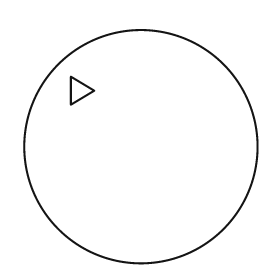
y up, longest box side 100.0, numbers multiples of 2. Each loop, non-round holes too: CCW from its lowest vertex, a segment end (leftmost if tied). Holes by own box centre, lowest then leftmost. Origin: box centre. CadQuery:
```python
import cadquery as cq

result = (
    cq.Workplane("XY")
    .moveTo(0.0, 0.0)
    .circle(50.0)
    .moveTo(-30.0, 18.0)
    .lineTo(-20.0, 24.0)
    .lineTo(-30.0, 30.0)
    .close()
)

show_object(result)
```